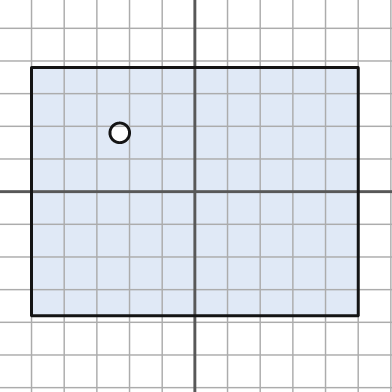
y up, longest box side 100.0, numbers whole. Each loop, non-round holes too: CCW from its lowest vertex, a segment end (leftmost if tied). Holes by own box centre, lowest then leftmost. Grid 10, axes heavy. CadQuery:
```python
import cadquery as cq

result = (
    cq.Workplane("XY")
    .moveTo(-50.0, -38.0)
    .lineTo(50.0, -38.0)
    .lineTo(50.0, 38.0)
    .lineTo(-50.0, 38.0)
    .close()
    .moveTo(-23.0, 18.0)
    .circle(3.0)
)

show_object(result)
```